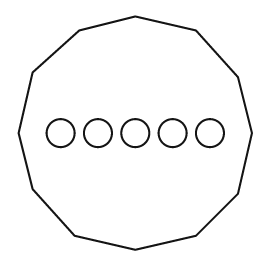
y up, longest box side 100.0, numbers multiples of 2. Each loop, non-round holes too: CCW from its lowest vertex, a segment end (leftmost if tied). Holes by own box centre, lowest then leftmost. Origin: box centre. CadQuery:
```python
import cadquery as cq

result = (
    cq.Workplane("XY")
    .moveTo(0.0, -50.0)
    .lineTo(26.0, -44.0)
    .lineTo(44.0, -26.0)
    .lineTo(50.0, 0.0)
    .lineTo(44.0, 24.0)
    .lineTo(26.0, 44.0)
    .lineTo(0.0, 50.0)
    .lineTo(-24.0, 44.0)
    .lineTo(-44.0, 26.0)
    .lineTo(-50.0, 0.0)
    .lineTo(-44.0, -24.0)
    .lineTo(-26.0, -44.0)
    .close()
    .moveTo(-32.0, 0.0)
    .circle(6.0)
    .moveTo(-16.0, 0.0)
    .circle(6.0)
    .moveTo(0.0, 0.0)
    .circle(6.0)
    .moveTo(16.0, 0.0)
    .circle(6.0)
    .moveTo(32.0, 0.0)
    .circle(6.0)
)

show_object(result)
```